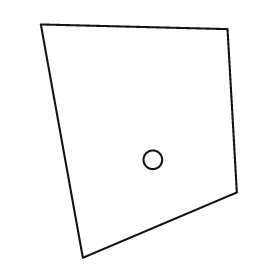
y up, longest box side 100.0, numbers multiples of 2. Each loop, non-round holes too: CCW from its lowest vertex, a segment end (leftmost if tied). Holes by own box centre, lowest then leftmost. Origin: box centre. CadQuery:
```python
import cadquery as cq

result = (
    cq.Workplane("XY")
    .moveTo(-24.0, -50.0)
    .lineTo(42.0, -22.0)
    .lineTo(38.0, 48.0)
    .lineTo(-42.0, 50.0)
    .close()
    .moveTo(6.0, -8.0)
    .circle(4.0)
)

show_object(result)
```